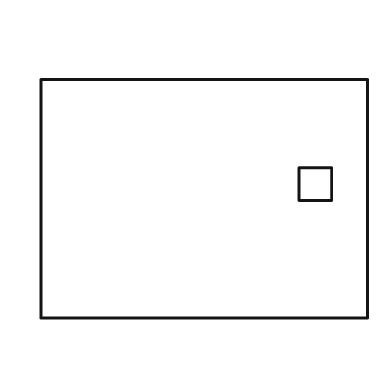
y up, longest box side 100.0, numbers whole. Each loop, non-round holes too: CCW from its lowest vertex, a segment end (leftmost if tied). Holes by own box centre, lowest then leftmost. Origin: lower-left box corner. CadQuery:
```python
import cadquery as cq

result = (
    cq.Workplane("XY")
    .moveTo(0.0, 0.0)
    .lineTo(100.0, 0.0)
    .lineTo(100.0, 73.0)
    .lineTo(0.0, 73.0)
    .close()
    .moveTo(79.0, 36.0)
    .lineTo(89.0, 36.0)
    .lineTo(89.0, 46.0)
    .lineTo(79.0, 46.0)
    .close()
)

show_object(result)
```